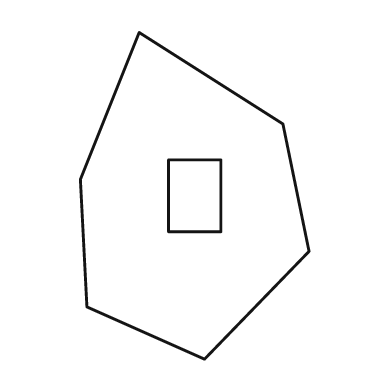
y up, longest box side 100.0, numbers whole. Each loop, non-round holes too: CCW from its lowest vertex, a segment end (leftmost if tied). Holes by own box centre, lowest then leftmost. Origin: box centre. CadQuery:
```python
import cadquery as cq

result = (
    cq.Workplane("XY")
    .moveTo(3.0, -50.0)
    .lineTo(35.0, -17.0)
    .lineTo(27.0, 22.0)
    .lineTo(-17.0, 50.0)
    .lineTo(-35.0, 5.0)
    .lineTo(-33.0, -34.0)
    .close()
    .moveTo(-8.0, -11.0)
    .lineTo(8.0, -11.0)
    .lineTo(8.0, 11.0)
    .lineTo(-8.0, 11.0)
    .close()
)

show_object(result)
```